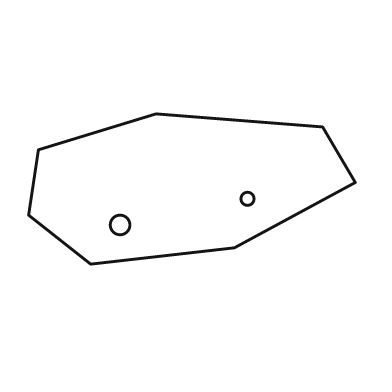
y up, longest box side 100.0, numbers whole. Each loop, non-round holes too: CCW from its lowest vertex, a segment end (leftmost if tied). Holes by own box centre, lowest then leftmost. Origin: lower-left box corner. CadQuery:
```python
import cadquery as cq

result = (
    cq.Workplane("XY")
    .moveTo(19.0, 0.0)
    .lineTo(63.0, 5.0)
    .lineTo(100.0, 25.0)
    .lineTo(90.0, 42.0)
    .lineTo(39.0, 46.0)
    .lineTo(3.0, 35.0)
    .lineTo(0.0, 15.0)
    .close()
    .moveTo(28.0, 12.0)
    .circle(3.0)
    .moveTo(67.0, 20.0)
    .circle(2.0)
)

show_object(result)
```